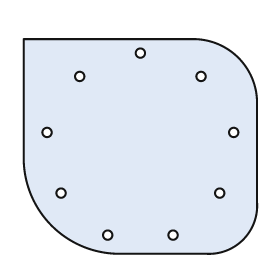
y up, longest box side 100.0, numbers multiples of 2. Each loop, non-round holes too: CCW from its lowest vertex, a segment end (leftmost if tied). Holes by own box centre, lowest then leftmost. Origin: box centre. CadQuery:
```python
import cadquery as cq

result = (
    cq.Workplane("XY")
    .moveTo(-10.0, -46.0)
    .lineTo(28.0, -46.0)
    .threePointArc((44.0, -40.0), (50.0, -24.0))
    .lineTo(50.0, 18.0)
    .threePointArc((42.0, 38.0), (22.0, 46.0))
    .lineTo(-50.0, 46.0)
    .lineTo(-50.0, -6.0)
    .threePointArc((-38.0, -34.0), (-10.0, -46.0))
    .close()
    .moveTo(-14.0, -38.0)
    .circle(2.0)
    .moveTo(14.0, -38.0)
    .circle(2.0)
    .moveTo(-34.0, -20.0)
    .circle(2.0)
    .moveTo(34.0, -20.0)
    .circle(2.0)
    .moveTo(-40.0, 6.0)
    .circle(2.0)
    .moveTo(40.0, 6.0)
    .circle(2.0)
    .moveTo(-26.0, 30.0)
    .circle(2.0)
    .moveTo(26.0, 30.0)
    .circle(2.0)
    .moveTo(0.0, 40.0)
    .circle(2.0)
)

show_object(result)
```